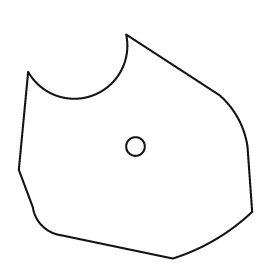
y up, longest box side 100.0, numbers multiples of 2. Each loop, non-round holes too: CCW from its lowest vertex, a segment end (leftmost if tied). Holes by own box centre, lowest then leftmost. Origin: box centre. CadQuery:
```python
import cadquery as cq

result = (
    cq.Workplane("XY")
    .moveTo(16.0, -48.0)
    .threePointArc((34.0, -40.0), (50.0, -28.0))
    .lineTo(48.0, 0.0)
    .threePointArc((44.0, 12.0), (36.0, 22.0))
    .lineTo(-4.0, 48.0)
    .threePointArc((-18.0, 22.0), (-46.0, 32.0))
    .lineTo(-50.0, -10.0)
    .lineTo(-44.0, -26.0)
    .threePointArc((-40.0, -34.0), (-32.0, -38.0))
    .close()
    .moveTo(0.0, 0.0)
    .circle(4.0)
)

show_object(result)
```